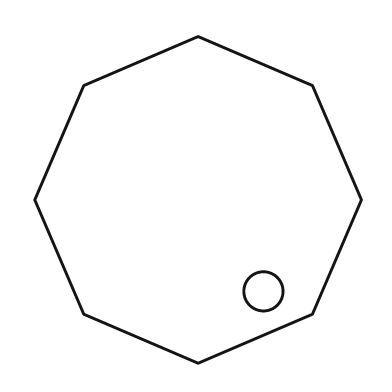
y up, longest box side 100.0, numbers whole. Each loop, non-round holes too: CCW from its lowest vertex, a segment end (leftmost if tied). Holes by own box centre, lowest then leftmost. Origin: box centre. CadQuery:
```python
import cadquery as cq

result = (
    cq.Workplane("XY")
    .moveTo(0.0, -50.0)
    .lineTo(35.0, -35.0)
    .lineTo(50.0, 0.0)
    .lineTo(35.0, 35.0)
    .lineTo(0.0, 50.0)
    .lineTo(-35.0, 35.0)
    .lineTo(-50.0, 0.0)
    .lineTo(-35.0, -35.0)
    .close()
    .moveTo(20.0, -28.0)
    .circle(6.0)
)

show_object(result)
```